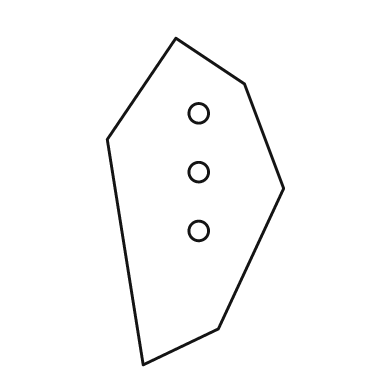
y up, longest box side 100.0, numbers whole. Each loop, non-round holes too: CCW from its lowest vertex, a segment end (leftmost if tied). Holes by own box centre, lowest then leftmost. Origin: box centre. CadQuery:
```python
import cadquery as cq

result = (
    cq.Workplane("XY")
    .moveTo(-16.0, -50.0)
    .lineTo(7.0, -39.0)
    .lineTo(27.0, 4.0)
    .lineTo(15.0, 36.0)
    .lineTo(-6.0, 50.0)
    .lineTo(-27.0, 19.0)
    .close()
    .moveTo(1.0, -9.0)
    .circle(3.0)
    .moveTo(1.0, 9.0)
    .circle(3.0)
    .moveTo(1.0, 27.0)
    .circle(3.0)
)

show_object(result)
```